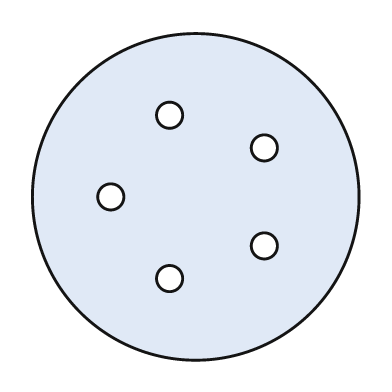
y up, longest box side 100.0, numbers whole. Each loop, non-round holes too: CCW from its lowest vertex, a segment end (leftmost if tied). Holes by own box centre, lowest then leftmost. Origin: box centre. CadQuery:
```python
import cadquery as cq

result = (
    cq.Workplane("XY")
    .moveTo(0.0, 0.0)
    .circle(50.0)
    .moveTo(-8.0, -25.0)
    .circle(4.0)
    .moveTo(21.0, -15.0)
    .circle(4.0)
    .moveTo(-26.0, 0.0)
    .circle(4.0)
    .moveTo(21.0, 15.0)
    .circle(4.0)
    .moveTo(-8.0, 25.0)
    .circle(4.0)
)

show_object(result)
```